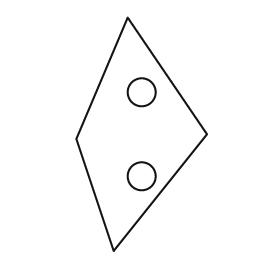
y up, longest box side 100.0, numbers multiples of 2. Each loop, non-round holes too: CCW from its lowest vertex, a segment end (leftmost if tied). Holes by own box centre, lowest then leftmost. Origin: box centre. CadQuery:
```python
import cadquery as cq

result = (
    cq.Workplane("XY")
    .moveTo(-12.0, -50.0)
    .lineTo(28.0, 0.0)
    .lineTo(-6.0, 50.0)
    .lineTo(-28.0, -2.0)
    .close()
    .moveTo(0.0, -18.0)
    .circle(6.0)
    .moveTo(0.0, 18.0)
    .circle(6.0)
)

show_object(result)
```